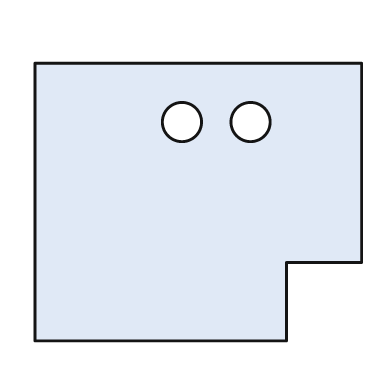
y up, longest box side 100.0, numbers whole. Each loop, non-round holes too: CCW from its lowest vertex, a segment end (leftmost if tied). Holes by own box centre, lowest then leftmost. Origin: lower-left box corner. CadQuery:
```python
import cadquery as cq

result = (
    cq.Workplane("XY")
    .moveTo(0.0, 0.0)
    .lineTo(77.0, 0.0)
    .lineTo(77.0, 24.0)
    .lineTo(100.0, 24.0)
    .lineTo(100.0, 85.0)
    .lineTo(0.0, 85.0)
    .close()
    .moveTo(45.0, 67.0)
    .circle(6.0)
    .moveTo(66.0, 67.0)
    .circle(6.0)
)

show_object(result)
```